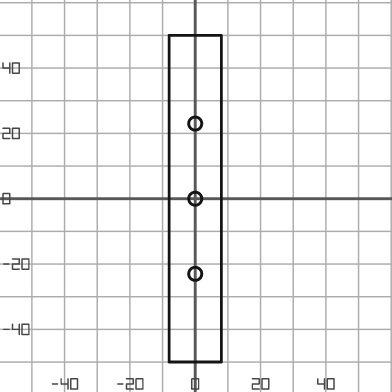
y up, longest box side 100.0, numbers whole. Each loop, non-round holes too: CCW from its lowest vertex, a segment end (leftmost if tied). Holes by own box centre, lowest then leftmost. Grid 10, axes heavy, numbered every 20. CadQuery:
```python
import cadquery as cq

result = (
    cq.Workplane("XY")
    .moveTo(-8.0, -50.0)
    .lineTo(8.0, -50.0)
    .lineTo(8.0, 50.0)
    .lineTo(-8.0, 50.0)
    .close()
    .moveTo(0.0, -23.0)
    .circle(2.0)
    .moveTo(0.0, 0.0)
    .circle(2.0)
    .moveTo(0.0, 23.0)
    .circle(2.0)
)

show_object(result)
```